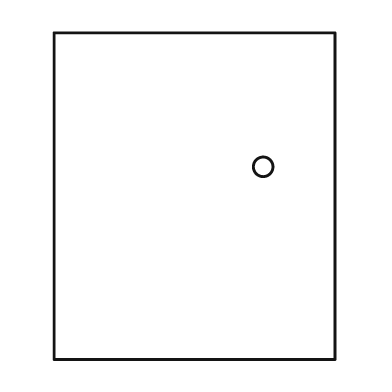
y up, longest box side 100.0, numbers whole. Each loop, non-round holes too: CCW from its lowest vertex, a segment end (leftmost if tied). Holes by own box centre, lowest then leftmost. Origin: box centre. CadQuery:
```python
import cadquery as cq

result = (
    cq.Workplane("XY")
    .moveTo(-43.0, -50.0)
    .lineTo(43.0, -50.0)
    .lineTo(43.0, 50.0)
    .lineTo(-43.0, 50.0)
    .close()
    .moveTo(21.0, 9.0)
    .circle(3.0)
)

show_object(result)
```